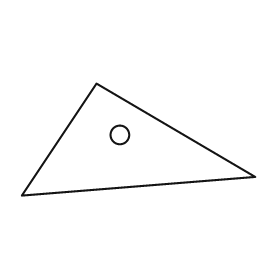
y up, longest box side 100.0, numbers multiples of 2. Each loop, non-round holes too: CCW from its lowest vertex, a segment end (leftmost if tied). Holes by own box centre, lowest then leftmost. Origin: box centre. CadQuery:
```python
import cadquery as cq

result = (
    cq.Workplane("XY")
    .moveTo(-50.0, -24.0)
    .lineTo(50.0, -16.0)
    .lineTo(-18.0, 24.0)
    .close()
    .moveTo(-8.0, 2.0)
    .circle(4.0)
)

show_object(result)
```